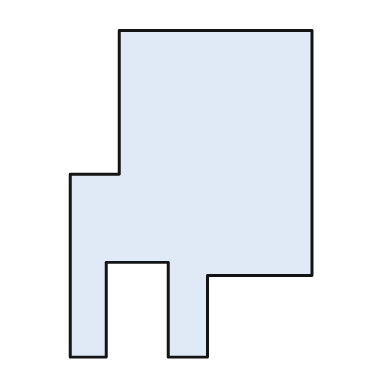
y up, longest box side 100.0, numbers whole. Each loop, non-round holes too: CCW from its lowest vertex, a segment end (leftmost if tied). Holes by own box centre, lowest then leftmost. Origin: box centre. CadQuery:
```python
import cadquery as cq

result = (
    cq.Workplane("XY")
    .moveTo(-37.0, -50.0)
    .lineTo(-26.0, -50.0)
    .lineTo(-26.0, -21.0)
    .lineTo(-7.0, -21.0)
    .lineTo(-7.0, -50.0)
    .lineTo(5.0, -50.0)
    .lineTo(5.0, -25.0)
    .lineTo(37.0, -25.0)
    .lineTo(37.0, 50.0)
    .lineTo(-22.0, 50.0)
    .lineTo(-22.0, 6.0)
    .lineTo(-37.0, 6.0)
    .close()
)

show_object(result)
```